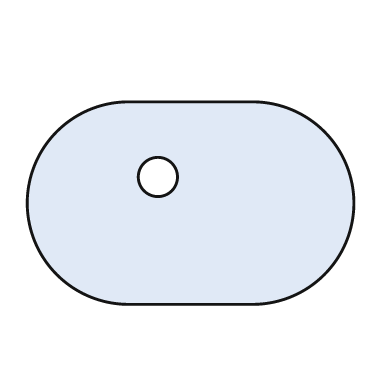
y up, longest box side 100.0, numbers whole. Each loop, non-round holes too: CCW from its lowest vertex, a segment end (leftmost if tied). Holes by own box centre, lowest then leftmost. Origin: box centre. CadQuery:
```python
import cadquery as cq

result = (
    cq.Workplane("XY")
    .moveTo(-19.0, -31.0)
    .lineTo(19.0, -31.0)
    .threePointArc((50.0, 0.0), (19.0, 31.0))
    .lineTo(-19.0, 31.0)
    .threePointArc((-50.0, 0.0), (-19.0, -31.0))
    .close()
    .moveTo(-10.0, 8.0)
    .circle(6.0)
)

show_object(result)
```